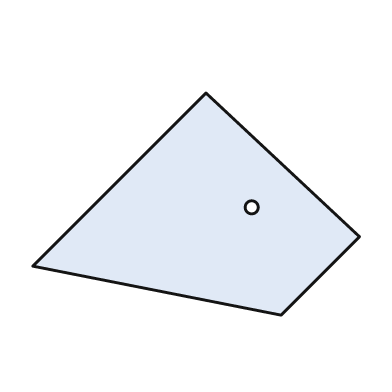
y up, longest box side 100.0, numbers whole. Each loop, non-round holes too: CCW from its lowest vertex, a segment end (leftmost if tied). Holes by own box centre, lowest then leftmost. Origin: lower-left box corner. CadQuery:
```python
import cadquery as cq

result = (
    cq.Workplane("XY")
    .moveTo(76.0, 0.0)
    .lineTo(100.0, 24.0)
    .lineTo(53.0, 68.0)
    .lineTo(0.0, 15.0)
    .close()
    .moveTo(67.0, 33.0)
    .circle(2.0)
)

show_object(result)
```